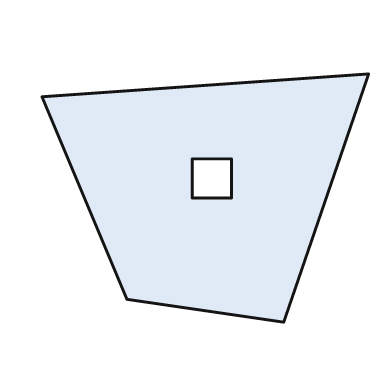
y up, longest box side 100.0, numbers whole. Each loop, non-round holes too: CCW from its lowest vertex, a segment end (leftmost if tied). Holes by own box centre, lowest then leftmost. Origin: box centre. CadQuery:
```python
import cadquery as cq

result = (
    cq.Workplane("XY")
    .moveTo(24.0, -38.0)
    .lineTo(50.0, 38.0)
    .lineTo(-50.0, 31.0)
    .lineTo(-24.0, -31.0)
    .close()
    .moveTo(-4.0, 0.0)
    .lineTo(8.0, 0.0)
    .lineTo(8.0, 12.0)
    .lineTo(-4.0, 12.0)
    .close()
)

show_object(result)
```